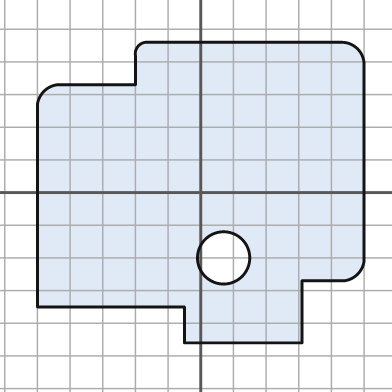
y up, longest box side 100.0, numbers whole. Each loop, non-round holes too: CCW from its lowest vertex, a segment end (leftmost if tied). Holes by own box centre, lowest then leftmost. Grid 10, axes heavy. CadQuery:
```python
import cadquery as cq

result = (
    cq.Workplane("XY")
    .moveTo(-5.0, -46.0)
    .lineTo(31.0, -46.0)
    .lineTo(31.0, -27.0)
    .lineTo(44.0, -27.0)
    .threePointArc((48.0, -25.0), (50.0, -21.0))
    .lineTo(50.0, 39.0)
    .threePointArc((48.0, 44.0), (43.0, 46.0))
    .lineTo(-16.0, 46.0)
    .threePointArc((-19.0, 45.0), (-20.0, 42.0))
    .lineTo(-20.0, 33.0)
    .lineTo(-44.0, 33.0)
    .threePointArc((-48.0, 31.0), (-50.0, 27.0))
    .lineTo(-50.0, -35.0)
    .lineTo(-5.0, -35.0)
    .close()
    .moveTo(7.0, -20.0)
    .circle(8.0)
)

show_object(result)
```